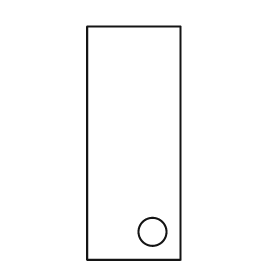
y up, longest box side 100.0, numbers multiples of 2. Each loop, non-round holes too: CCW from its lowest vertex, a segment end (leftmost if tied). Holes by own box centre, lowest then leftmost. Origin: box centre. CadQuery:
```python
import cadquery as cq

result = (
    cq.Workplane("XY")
    .moveTo(-20.0, -50.0)
    .lineTo(20.0, -50.0)
    .lineTo(20.0, 50.0)
    .lineTo(-20.0, 50.0)
    .close()
    .moveTo(8.0, -38.0)
    .circle(6.0)
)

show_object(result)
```